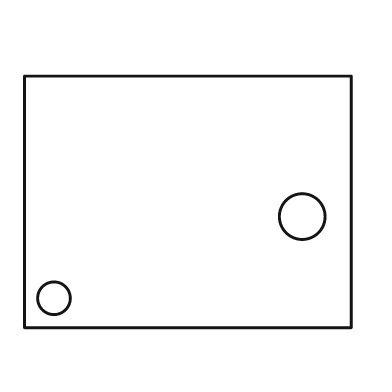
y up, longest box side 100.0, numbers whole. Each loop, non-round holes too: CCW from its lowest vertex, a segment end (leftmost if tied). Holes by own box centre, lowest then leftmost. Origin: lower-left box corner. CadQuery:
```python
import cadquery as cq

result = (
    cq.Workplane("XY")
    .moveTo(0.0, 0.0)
    .lineTo(100.0, 0.0)
    .lineTo(100.0, 77.0)
    .lineTo(0.0, 77.0)
    .close()
    .moveTo(9.0, 9.0)
    .circle(5.0)
    .moveTo(85.0, 34.0)
    .circle(7.0)
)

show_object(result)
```